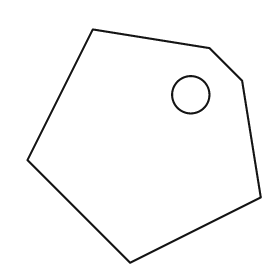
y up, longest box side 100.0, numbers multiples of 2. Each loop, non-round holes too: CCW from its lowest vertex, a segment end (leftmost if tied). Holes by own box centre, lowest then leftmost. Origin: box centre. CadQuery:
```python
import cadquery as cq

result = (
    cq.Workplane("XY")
    .moveTo(-6.0, -50.0)
    .lineTo(50.0, -22.0)
    .lineTo(42.0, 28.0)
    .lineTo(28.0, 42.0)
    .lineTo(-22.0, 50.0)
    .lineTo(-50.0, -6.0)
    .close()
    .moveTo(20.0, 22.0)
    .circle(8.0)
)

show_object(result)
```